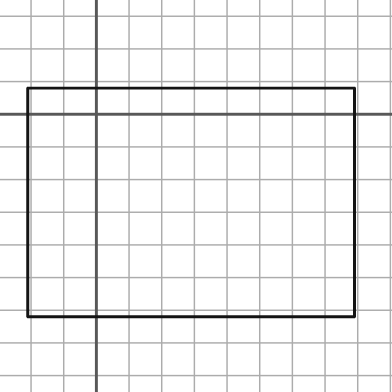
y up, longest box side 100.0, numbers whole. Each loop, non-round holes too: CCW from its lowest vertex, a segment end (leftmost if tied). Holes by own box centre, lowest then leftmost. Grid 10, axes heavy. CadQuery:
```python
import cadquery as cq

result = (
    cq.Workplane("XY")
    .moveTo(-21.0, -62.0)
    .lineTo(79.0, -62.0)
    .lineTo(79.0, 8.0)
    .lineTo(-21.0, 8.0)
    .close()
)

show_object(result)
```